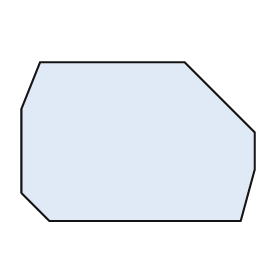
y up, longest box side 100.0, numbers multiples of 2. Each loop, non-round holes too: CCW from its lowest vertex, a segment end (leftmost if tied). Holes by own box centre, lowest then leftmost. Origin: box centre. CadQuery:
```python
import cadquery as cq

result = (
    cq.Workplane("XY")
    .moveTo(-38.0, -34.0)
    .lineTo(44.0, -34.0)
    .lineTo(50.0, -12.0)
    .lineTo(50.0, 4.0)
    .lineTo(20.0, 34.0)
    .lineTo(-42.0, 34.0)
    .lineTo(-50.0, 14.0)
    .lineTo(-50.0, -22.0)
    .close()
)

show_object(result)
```